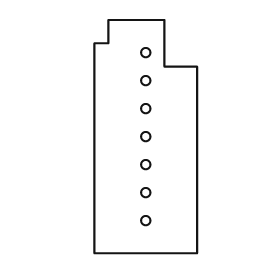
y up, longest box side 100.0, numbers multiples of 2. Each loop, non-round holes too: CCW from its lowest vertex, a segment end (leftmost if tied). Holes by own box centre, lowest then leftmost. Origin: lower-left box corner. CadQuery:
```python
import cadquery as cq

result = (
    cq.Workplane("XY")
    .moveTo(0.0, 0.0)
    .lineTo(44.0, 0.0)
    .lineTo(44.0, 80.0)
    .lineTo(30.0, 80.0)
    .lineTo(30.0, 100.0)
    .lineTo(6.0, 100.0)
    .lineTo(6.0, 90.0)
    .lineTo(0.0, 90.0)
    .close()
    .moveTo(22.0, 14.0)
    .circle(2.0)
    .moveTo(22.0, 26.0)
    .circle(2.0)
    .moveTo(22.0, 38.0)
    .circle(2.0)
    .moveTo(22.0, 50.0)
    .circle(2.0)
    .moveTo(22.0, 62.0)
    .circle(2.0)
    .moveTo(22.0, 74.0)
    .circle(2.0)
    .moveTo(22.0, 86.0)
    .circle(2.0)
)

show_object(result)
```